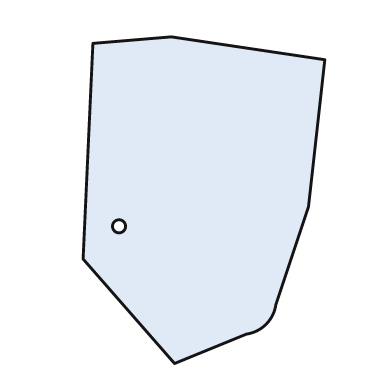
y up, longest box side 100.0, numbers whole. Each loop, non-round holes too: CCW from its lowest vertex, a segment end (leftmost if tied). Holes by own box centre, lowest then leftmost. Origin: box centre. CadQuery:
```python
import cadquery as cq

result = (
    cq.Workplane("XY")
    .moveTo(-9.0, -50.0)
    .lineTo(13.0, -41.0)
    .threePointArc((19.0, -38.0), (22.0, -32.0))
    .lineTo(32.0, -2.0)
    .lineTo(37.0, 43.0)
    .lineTo(-10.0, 50.0)
    .lineTo(-34.0, 48.0)
    .lineTo(-37.0, -18.0)
    .close()
    .moveTo(-26.0, -8.0)
    .circle(2.0)
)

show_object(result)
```